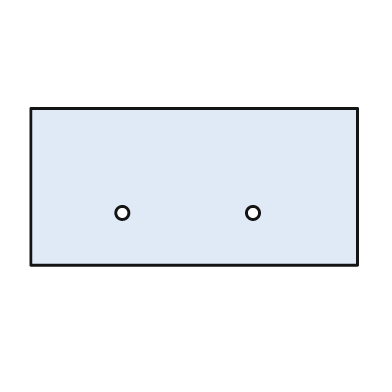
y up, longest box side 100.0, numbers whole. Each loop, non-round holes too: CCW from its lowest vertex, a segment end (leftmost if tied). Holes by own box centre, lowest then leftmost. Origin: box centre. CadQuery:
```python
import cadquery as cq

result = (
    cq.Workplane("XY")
    .moveTo(-50.0, -24.0)
    .lineTo(50.0, -24.0)
    .lineTo(50.0, 24.0)
    .lineTo(-50.0, 24.0)
    .close()
    .moveTo(-22.0, -8.0)
    .circle(2.0)
    .moveTo(18.0, -8.0)
    .circle(2.0)
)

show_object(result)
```